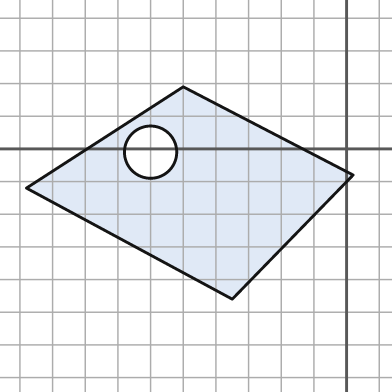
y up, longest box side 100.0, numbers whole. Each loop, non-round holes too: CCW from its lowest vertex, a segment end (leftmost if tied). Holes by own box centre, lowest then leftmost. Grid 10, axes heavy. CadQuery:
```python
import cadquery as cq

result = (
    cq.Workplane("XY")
    .moveTo(-35.0, -46.0)
    .lineTo(2.0, -8.0)
    .lineTo(-50.0, 19.0)
    .lineTo(-98.0, -12.0)
    .close()
    .moveTo(-60.0, -1.0)
    .circle(8.0)
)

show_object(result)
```